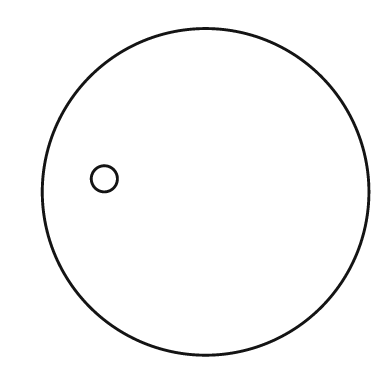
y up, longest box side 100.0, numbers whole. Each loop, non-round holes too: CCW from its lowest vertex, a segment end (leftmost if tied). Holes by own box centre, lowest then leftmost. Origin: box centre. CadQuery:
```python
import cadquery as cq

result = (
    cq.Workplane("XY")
    .moveTo(0.0, 0.0)
    .circle(50.0)
    .moveTo(-31.0, 4.0)
    .circle(4.0)
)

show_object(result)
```